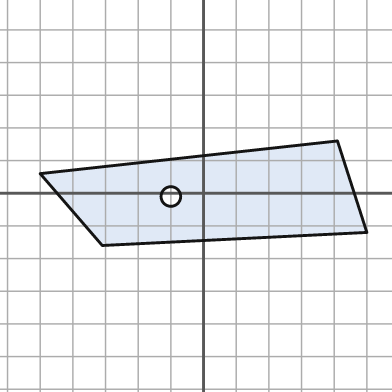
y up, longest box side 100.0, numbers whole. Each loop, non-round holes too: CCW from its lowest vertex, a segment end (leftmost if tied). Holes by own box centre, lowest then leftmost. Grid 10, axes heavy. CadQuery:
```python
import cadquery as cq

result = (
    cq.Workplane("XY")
    .moveTo(-31.0, -16.0)
    .lineTo(50.0, -12.0)
    .lineTo(41.0, 16.0)
    .lineTo(-50.0, 6.0)
    .close()
    .moveTo(-10.0, -1.0)
    .circle(3.0)
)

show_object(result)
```